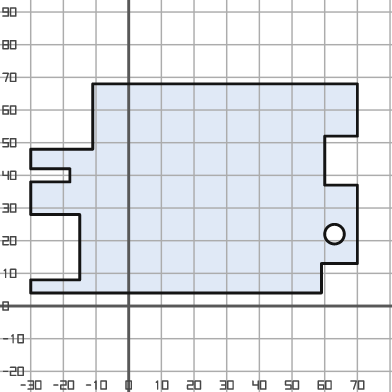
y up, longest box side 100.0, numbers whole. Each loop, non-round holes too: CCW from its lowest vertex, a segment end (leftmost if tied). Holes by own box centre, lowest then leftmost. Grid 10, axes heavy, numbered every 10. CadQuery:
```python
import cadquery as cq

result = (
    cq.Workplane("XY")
    .moveTo(-30.0, 4.0)
    .lineTo(59.0, 4.0)
    .lineTo(59.0, 13.0)
    .lineTo(70.0, 13.0)
    .lineTo(70.0, 37.0)
    .lineTo(60.0, 37.0)
    .lineTo(60.0, 52.0)
    .lineTo(70.0, 52.0)
    .lineTo(70.0, 68.0)
    .lineTo(-11.0, 68.0)
    .lineTo(-11.0, 48.0)
    .lineTo(-30.0, 48.0)
    .lineTo(-30.0, 42.0)
    .lineTo(-18.0, 42.0)
    .lineTo(-18.0, 38.0)
    .lineTo(-30.0, 38.0)
    .lineTo(-30.0, 28.0)
    .lineTo(-15.0, 28.0)
    .lineTo(-15.0, 8.0)
    .lineTo(-30.0, 8.0)
    .close()
    .moveTo(63.0, 22.0)
    .circle(3.0)
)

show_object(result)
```